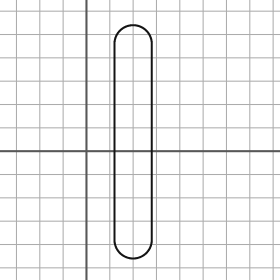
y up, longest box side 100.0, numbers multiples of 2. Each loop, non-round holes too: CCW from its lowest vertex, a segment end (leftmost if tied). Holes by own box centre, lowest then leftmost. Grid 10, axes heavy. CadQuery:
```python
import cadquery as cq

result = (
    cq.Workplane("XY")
    .moveTo(12.0, -38.0)
    .threePointArc((20.0, -46.0), (28.0, -38.0))
    .lineTo(28.0, 46.0)
    .threePointArc((20.0, 54.0), (12.0, 46.0))
    .close()
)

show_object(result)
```